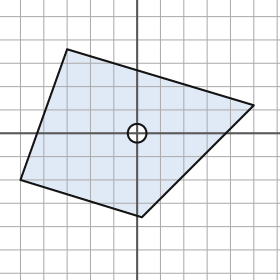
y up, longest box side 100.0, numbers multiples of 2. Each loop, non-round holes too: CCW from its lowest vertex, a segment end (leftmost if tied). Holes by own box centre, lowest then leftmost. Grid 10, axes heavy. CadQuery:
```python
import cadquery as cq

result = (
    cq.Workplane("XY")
    .moveTo(2.0, -36.0)
    .lineTo(50.0, 12.0)
    .lineTo(-30.0, 36.0)
    .lineTo(-50.0, -20.0)
    .close()
    .moveTo(0.0, 0.0)
    .circle(4.0)
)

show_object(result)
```